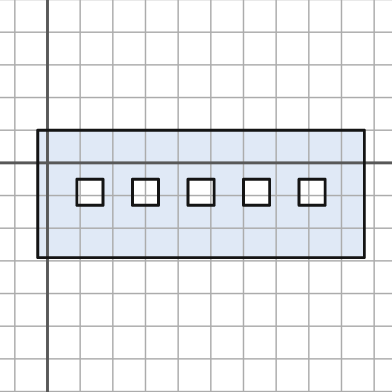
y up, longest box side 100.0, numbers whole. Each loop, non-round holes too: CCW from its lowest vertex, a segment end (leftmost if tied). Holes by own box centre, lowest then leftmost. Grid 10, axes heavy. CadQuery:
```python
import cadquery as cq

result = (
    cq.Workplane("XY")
    .moveTo(-3.0, -29.0)
    .lineTo(97.0, -29.0)
    .lineTo(97.0, 10.0)
    .lineTo(-3.0, 10.0)
    .close()
    .moveTo(9.0, -13.0)
    .lineTo(17.0, -13.0)
    .lineTo(17.0, -5.0)
    .lineTo(9.0, -5.0)
    .close()
    .moveTo(26.0, -13.0)
    .lineTo(34.0, -13.0)
    .lineTo(34.0, -5.0)
    .lineTo(26.0, -5.0)
    .close()
    .moveTo(43.0, -13.0)
    .lineTo(51.0, -13.0)
    .lineTo(51.0, -5.0)
    .lineTo(43.0, -5.0)
    .close()
    .moveTo(60.0, -13.0)
    .lineTo(68.0, -13.0)
    .lineTo(68.0, -5.0)
    .lineTo(60.0, -5.0)
    .close()
    .moveTo(77.0, -13.0)
    .lineTo(85.0, -13.0)
    .lineTo(85.0, -5.0)
    .lineTo(77.0, -5.0)
    .close()
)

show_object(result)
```